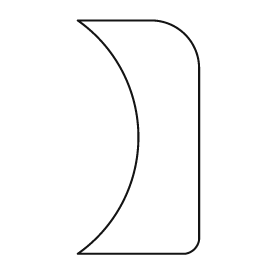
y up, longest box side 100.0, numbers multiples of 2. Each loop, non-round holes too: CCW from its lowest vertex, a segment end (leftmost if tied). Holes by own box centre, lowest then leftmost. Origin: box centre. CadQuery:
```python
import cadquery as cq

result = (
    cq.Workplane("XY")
    .moveTo(-26.0, -50.0)
    .lineTo(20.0, -50.0)
    .threePointArc((24.0, -48.0), (26.0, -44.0))
    .lineTo(26.0, 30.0)
    .threePointArc((20.0, 44.0), (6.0, 50.0))
    .lineTo(-26.0, 50.0)
    .threePointArc((0.0, 0.0), (-26.0, -50.0))
    .close()
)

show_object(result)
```